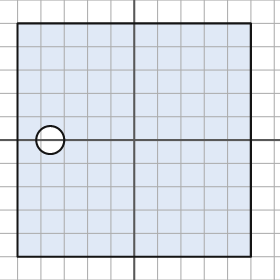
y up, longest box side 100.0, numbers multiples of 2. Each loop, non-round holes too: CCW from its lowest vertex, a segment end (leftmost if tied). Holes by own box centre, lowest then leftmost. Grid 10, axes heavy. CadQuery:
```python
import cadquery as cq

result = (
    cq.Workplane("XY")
    .moveTo(-50.0, -50.0)
    .lineTo(50.0, -50.0)
    .lineTo(50.0, 50.0)
    .lineTo(-50.0, 50.0)
    .close()
    .moveTo(-36.0, 0.0)
    .circle(6.0)
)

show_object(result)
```